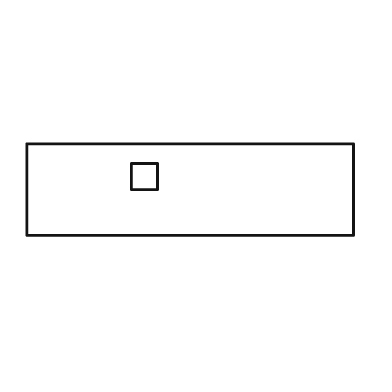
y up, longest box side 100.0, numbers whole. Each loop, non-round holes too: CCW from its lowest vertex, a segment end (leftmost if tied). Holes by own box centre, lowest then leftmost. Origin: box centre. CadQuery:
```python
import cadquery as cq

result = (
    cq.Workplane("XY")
    .moveTo(-50.0, -14.0)
    .lineTo(50.0, -14.0)
    .lineTo(50.0, 14.0)
    .lineTo(-50.0, 14.0)
    .close()
    .moveTo(-18.0, 0.0)
    .lineTo(-10.0, 0.0)
    .lineTo(-10.0, 8.0)
    .lineTo(-18.0, 8.0)
    .close()
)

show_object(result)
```